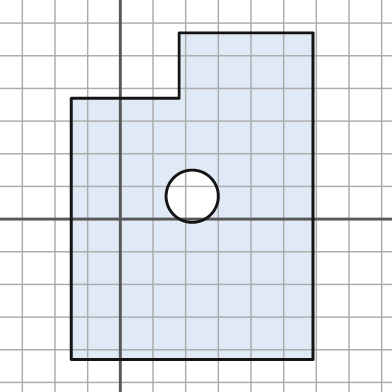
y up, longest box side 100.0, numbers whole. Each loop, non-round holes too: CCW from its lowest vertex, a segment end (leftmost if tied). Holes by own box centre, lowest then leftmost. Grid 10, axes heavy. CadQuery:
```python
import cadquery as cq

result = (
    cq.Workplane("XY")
    .moveTo(-15.0, -43.0)
    .lineTo(59.0, -43.0)
    .lineTo(59.0, 57.0)
    .lineTo(18.0, 57.0)
    .lineTo(18.0, 37.0)
    .lineTo(-15.0, 37.0)
    .close()
    .moveTo(22.0, 7.0)
    .circle(8.0)
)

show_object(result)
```